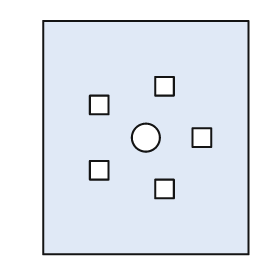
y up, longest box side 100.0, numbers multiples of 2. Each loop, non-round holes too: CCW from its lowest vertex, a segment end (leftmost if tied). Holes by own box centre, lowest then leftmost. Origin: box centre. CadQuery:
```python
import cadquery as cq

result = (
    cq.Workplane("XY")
    .moveTo(-44.0, -50.0)
    .lineTo(44.0, -50.0)
    .lineTo(44.0, 50.0)
    .lineTo(-44.0, 50.0)
    .close()
    .moveTo(4.0, -26.0)
    .lineTo(12.0, -26.0)
    .lineTo(12.0, -18.0)
    .lineTo(4.0, -18.0)
    .close()
    .moveTo(-24.0, -18.0)
    .lineTo(-16.0, -18.0)
    .lineTo(-16.0, -10.0)
    .lineTo(-24.0, -10.0)
    .close()
    .moveTo(0.0, 0.0)
    .circle(6.0)
    .moveTo(20.0, -4.0)
    .lineTo(28.0, -4.0)
    .lineTo(28.0, 4.0)
    .lineTo(20.0, 4.0)
    .close()
    .moveTo(-24.0, 10.0)
    .lineTo(-16.0, 10.0)
    .lineTo(-16.0, 18.0)
    .lineTo(-24.0, 18.0)
    .close()
    .moveTo(4.0, 18.0)
    .lineTo(12.0, 18.0)
    .lineTo(12.0, 26.0)
    .lineTo(4.0, 26.0)
    .close()
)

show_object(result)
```